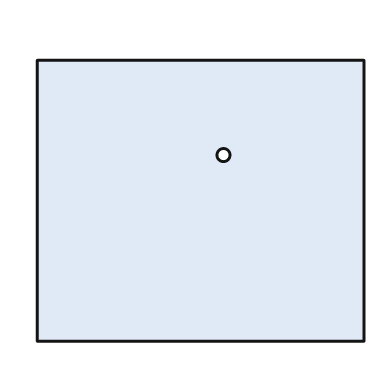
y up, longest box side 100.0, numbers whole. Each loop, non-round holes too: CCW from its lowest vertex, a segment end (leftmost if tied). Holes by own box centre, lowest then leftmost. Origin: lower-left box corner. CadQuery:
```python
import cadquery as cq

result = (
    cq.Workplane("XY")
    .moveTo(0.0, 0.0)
    .lineTo(100.0, 0.0)
    .lineTo(100.0, 86.0)
    .lineTo(0.0, 86.0)
    .close()
    .moveTo(57.0, 57.0)
    .circle(2.0)
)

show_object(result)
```